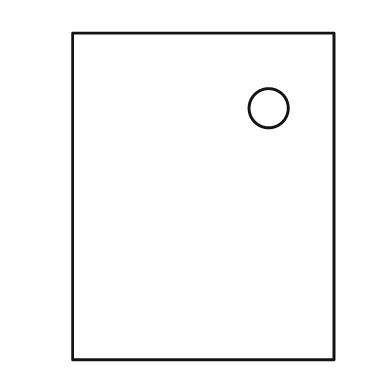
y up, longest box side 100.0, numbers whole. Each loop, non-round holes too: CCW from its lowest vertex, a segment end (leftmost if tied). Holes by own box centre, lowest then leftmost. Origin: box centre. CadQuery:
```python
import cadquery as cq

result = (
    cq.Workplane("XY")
    .moveTo(-40.0, -50.0)
    .lineTo(40.0, -50.0)
    .lineTo(40.0, 50.0)
    .lineTo(-40.0, 50.0)
    .close()
    .moveTo(20.0, 27.0)
    .circle(6.0)
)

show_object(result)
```